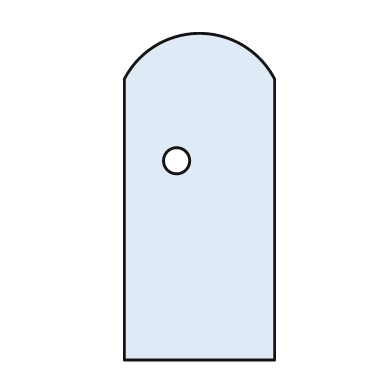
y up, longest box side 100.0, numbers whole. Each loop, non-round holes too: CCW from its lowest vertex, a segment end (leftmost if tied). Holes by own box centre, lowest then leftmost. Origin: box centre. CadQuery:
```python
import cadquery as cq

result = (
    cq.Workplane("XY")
    .moveTo(-23.0, -50.0)
    .lineTo(23.0, -50.0)
    .lineTo(23.0, 36.0)
    .threePointArc((0.0, 50.0), (-23.0, 36.0))
    .close()
    .moveTo(-7.0, 11.0)
    .circle(4.0)
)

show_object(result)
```